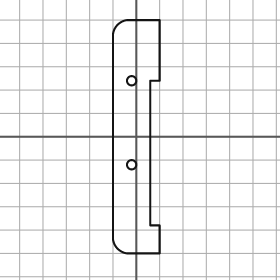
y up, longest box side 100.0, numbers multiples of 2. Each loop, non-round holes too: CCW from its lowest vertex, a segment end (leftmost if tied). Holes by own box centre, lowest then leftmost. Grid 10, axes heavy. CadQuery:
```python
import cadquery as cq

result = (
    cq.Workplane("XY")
    .moveTo(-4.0, -50.0)
    .lineTo(10.0, -50.0)
    .lineTo(10.0, -38.0)
    .lineTo(6.0, -38.0)
    .lineTo(6.0, 24.0)
    .lineTo(10.0, 24.0)
    .lineTo(10.0, 50.0)
    .lineTo(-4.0, 50.0)
    .threePointArc((-8.0, 48.0), (-10.0, 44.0))
    .lineTo(-10.0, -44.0)
    .threePointArc((-8.0, -48.0), (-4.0, -50.0))
    .close()
    .moveTo(-2.0, -12.0)
    .circle(2.0)
    .moveTo(-2.0, 24.0)
    .circle(2.0)
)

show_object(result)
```